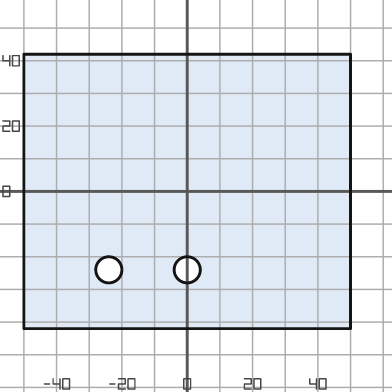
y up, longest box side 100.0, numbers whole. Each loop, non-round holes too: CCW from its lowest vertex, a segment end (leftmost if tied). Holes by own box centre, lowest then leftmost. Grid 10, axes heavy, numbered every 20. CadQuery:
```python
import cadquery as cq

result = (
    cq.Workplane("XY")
    .moveTo(-50.0, -42.0)
    .lineTo(50.0, -42.0)
    .lineTo(50.0, 42.0)
    .lineTo(-50.0, 42.0)
    .close()
    .moveTo(-24.0, -24.0)
    .circle(4.0)
    .moveTo(0.0, -24.0)
    .circle(4.0)
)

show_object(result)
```